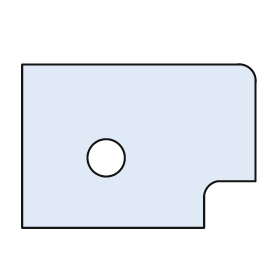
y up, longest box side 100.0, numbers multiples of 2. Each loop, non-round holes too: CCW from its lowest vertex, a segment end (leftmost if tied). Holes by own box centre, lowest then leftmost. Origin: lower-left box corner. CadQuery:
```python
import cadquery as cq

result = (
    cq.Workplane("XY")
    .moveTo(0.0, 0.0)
    .lineTo(78.0, 0.0)
    .lineTo(78.0, 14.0)
    .threePointArc((80.0, 18.0), (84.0, 20.0))
    .lineTo(100.0, 20.0)
    .lineTo(100.0, 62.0)
    .threePointArc((98.0, 68.0), (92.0, 70.0))
    .lineTo(0.0, 70.0)
    .close()
    .moveTo(36.0, 30.0)
    .circle(8.0)
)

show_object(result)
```